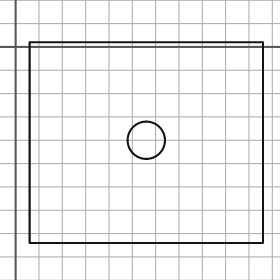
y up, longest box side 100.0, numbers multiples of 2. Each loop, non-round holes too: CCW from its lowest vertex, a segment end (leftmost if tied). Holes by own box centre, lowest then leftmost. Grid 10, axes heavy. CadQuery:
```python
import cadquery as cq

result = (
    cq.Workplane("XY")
    .moveTo(6.0, -84.0)
    .lineTo(106.0, -84.0)
    .lineTo(106.0, 2.0)
    .lineTo(6.0, 2.0)
    .close()
    .moveTo(56.0, -40.0)
    .circle(8.0)
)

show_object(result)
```